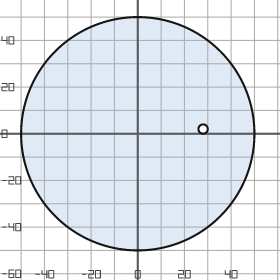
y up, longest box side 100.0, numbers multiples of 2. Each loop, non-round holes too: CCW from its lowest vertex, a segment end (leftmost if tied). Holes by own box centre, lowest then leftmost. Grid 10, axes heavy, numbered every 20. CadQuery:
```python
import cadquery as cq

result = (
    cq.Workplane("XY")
    .moveTo(0.0, 0.0)
    .circle(50.0)
    .moveTo(28.0, 2.0)
    .circle(2.0)
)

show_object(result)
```